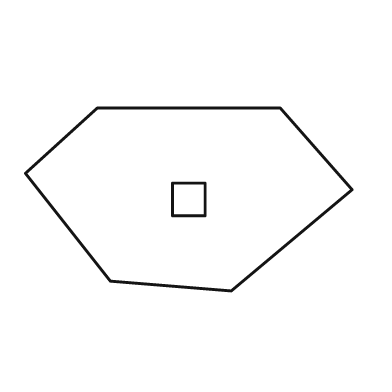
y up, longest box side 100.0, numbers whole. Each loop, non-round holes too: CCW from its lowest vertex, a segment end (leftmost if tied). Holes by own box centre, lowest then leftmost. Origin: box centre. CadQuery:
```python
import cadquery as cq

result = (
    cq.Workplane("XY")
    .moveTo(13.0, -28.0)
    .lineTo(50.0, 3.0)
    .lineTo(28.0, 28.0)
    .lineTo(-28.0, 28.0)
    .lineTo(-50.0, 8.0)
    .lineTo(-24.0, -25.0)
    .close()
    .moveTo(-5.0, -5.0)
    .lineTo(5.0, -5.0)
    .lineTo(5.0, 5.0)
    .lineTo(-5.0, 5.0)
    .close()
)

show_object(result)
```